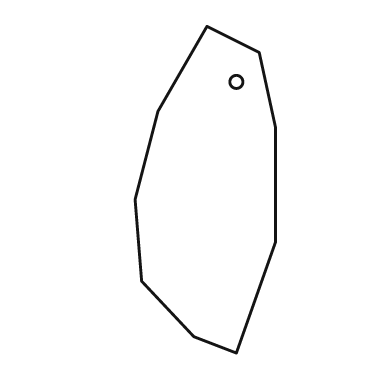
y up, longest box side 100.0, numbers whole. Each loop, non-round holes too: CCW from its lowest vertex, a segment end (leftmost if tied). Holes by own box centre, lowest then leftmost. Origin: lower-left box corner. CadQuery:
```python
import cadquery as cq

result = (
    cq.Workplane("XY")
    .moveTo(31.0, 0.0)
    .lineTo(43.0, 34.0)
    .lineTo(43.0, 69.0)
    .lineTo(38.0, 92.0)
    .lineTo(22.0, 100.0)
    .lineTo(7.0, 74.0)
    .lineTo(0.0, 47.0)
    .lineTo(2.0, 22.0)
    .lineTo(18.0, 5.0)
    .close()
    .moveTo(31.0, 83.0)
    .circle(2.0)
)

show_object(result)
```